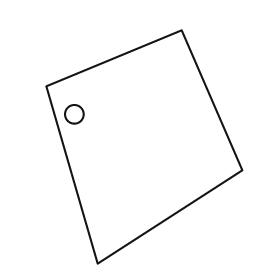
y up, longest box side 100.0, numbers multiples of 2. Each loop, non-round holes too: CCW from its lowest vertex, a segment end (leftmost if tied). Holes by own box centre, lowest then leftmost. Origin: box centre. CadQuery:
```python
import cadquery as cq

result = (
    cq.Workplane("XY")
    .moveTo(-20.0, -50.0)
    .lineTo(42.0, -10.0)
    .lineTo(16.0, 50.0)
    .lineTo(-42.0, 26.0)
    .close()
    .moveTo(-30.0, 14.0)
    .circle(4.0)
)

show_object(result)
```